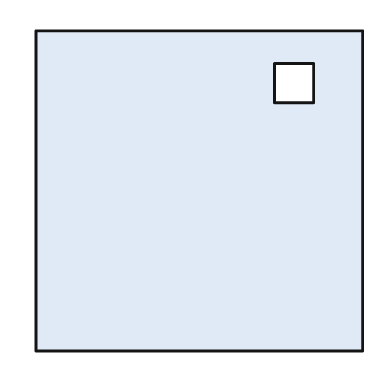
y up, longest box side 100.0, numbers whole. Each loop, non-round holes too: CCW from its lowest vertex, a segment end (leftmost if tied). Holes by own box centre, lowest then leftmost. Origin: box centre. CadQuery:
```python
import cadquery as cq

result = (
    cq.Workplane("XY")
    .moveTo(-50.0, -49.0)
    .lineTo(50.0, -49.0)
    .lineTo(50.0, 49.0)
    .lineTo(-50.0, 49.0)
    .close()
    .moveTo(23.0, 27.0)
    .lineTo(35.0, 27.0)
    .lineTo(35.0, 39.0)
    .lineTo(23.0, 39.0)
    .close()
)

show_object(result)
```